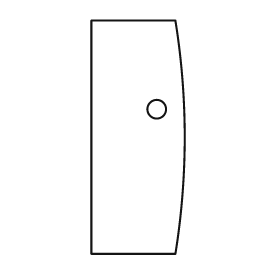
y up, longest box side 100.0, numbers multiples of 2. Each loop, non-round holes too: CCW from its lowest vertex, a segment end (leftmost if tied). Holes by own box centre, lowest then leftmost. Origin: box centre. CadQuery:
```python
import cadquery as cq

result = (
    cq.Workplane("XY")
    .moveTo(-20.0, -50.0)
    .lineTo(16.0, -50.0)
    .threePointArc((20.0, 0.0), (16.0, 50.0))
    .lineTo(-20.0, 50.0)
    .close()
    .moveTo(8.0, 12.0)
    .circle(4.0)
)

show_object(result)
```